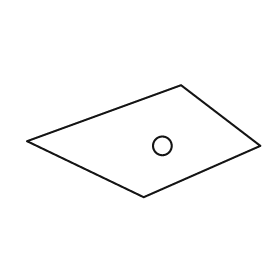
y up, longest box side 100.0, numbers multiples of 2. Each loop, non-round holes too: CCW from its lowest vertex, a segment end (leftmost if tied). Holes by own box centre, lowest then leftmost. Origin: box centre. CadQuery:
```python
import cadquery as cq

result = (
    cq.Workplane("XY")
    .moveTo(0.0, -24.0)
    .lineTo(50.0, -2.0)
    .lineTo(16.0, 24.0)
    .lineTo(-50.0, 0.0)
    .close()
    .moveTo(8.0, -2.0)
    .circle(4.0)
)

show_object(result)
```